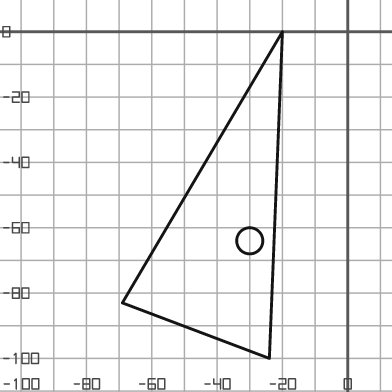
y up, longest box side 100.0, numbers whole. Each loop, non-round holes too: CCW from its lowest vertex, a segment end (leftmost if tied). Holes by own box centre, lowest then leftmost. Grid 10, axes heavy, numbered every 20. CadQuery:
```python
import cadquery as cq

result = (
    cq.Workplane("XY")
    .moveTo(-24.0, -100.0)
    .lineTo(-20.0, 0.0)
    .lineTo(-69.0, -83.0)
    .close()
    .moveTo(-30.0, -64.0)
    .circle(4.0)
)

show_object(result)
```